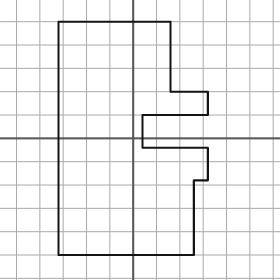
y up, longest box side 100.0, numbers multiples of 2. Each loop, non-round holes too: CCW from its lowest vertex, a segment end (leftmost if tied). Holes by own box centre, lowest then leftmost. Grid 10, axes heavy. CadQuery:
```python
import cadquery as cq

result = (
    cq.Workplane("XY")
    .moveTo(-32.0, -50.0)
    .lineTo(26.0, -50.0)
    .lineTo(26.0, -18.0)
    .lineTo(32.0, -18.0)
    .lineTo(32.0, -4.0)
    .lineTo(4.0, -4.0)
    .lineTo(4.0, 10.0)
    .lineTo(32.0, 10.0)
    .lineTo(32.0, 20.0)
    .lineTo(16.0, 20.0)
    .lineTo(16.0, 50.0)
    .lineTo(-32.0, 50.0)
    .close()
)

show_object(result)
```